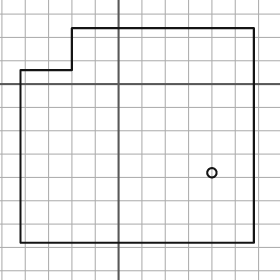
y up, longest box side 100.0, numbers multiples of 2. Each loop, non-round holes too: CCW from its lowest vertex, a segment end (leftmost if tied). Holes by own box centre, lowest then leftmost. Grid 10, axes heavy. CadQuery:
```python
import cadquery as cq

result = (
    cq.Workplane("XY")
    .moveTo(-42.0, -68.0)
    .lineTo(58.0, -68.0)
    .lineTo(58.0, 24.0)
    .lineTo(-20.0, 24.0)
    .lineTo(-20.0, 6.0)
    .lineTo(-42.0, 6.0)
    .close()
    .moveTo(40.0, -38.0)
    .circle(2.0)
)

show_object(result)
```